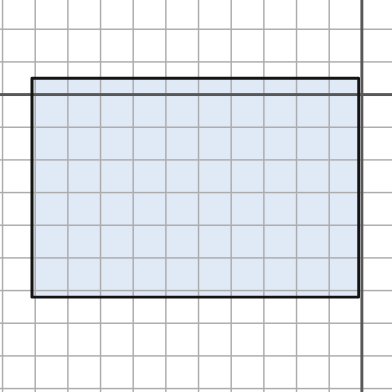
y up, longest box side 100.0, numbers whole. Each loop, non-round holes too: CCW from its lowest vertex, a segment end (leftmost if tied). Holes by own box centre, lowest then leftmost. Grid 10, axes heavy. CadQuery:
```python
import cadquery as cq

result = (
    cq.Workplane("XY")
    .moveTo(-101.0, -62.0)
    .lineTo(-1.0, -62.0)
    .lineTo(-1.0, 5.0)
    .lineTo(-101.0, 5.0)
    .close()
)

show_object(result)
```